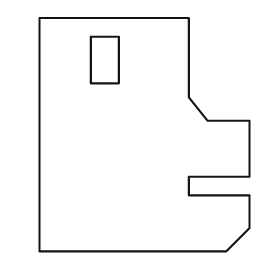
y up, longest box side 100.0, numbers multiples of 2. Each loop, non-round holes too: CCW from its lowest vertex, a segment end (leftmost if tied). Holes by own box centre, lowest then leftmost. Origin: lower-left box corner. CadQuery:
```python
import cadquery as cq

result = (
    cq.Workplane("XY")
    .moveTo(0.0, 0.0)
    .lineTo(80.0, 0.0)
    .lineTo(90.0, 10.0)
    .lineTo(90.0, 24.0)
    .lineTo(64.0, 24.0)
    .lineTo(64.0, 32.0)
    .lineTo(90.0, 32.0)
    .lineTo(90.0, 56.0)
    .lineTo(72.0, 56.0)
    .lineTo(64.0, 66.0)
    .lineTo(64.0, 100.0)
    .lineTo(0.0, 100.0)
    .close()
    .moveTo(22.0, 72.0)
    .lineTo(34.0, 72.0)
    .lineTo(34.0, 92.0)
    .lineTo(22.0, 92.0)
    .close()
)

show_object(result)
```